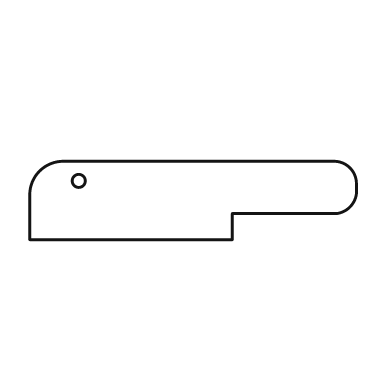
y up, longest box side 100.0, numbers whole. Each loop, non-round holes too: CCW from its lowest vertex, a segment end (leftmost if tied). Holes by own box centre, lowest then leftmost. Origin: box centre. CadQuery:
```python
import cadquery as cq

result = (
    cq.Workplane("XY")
    .moveTo(-50.0, -12.0)
    .lineTo(12.0, -12.0)
    .lineTo(12.0, -4.0)
    .lineTo(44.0, -4.0)
    .threePointArc((48.0, -2.0), (50.0, 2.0))
    .lineTo(50.0, 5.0)
    .threePointArc((48.0, 10.0), (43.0, 12.0))
    .lineTo(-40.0, 12.0)
    .threePointArc((-47.0, 9.0), (-50.0, 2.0))
    .close()
    .moveTo(-35.0, 6.0)
    .circle(2.0)
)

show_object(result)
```